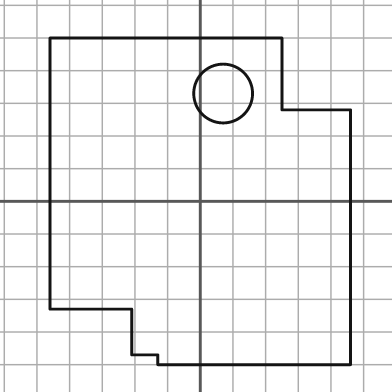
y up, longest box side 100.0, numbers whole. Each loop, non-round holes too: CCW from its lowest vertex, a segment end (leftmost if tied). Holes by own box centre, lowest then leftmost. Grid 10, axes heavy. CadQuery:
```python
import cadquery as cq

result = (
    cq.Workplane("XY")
    .moveTo(-13.0, -50.0)
    .lineTo(46.0, -50.0)
    .lineTo(46.0, 28.0)
    .lineTo(25.0, 28.0)
    .lineTo(25.0, 50.0)
    .lineTo(-46.0, 50.0)
    .lineTo(-46.0, -33.0)
    .lineTo(-21.0, -33.0)
    .lineTo(-21.0, -47.0)
    .lineTo(-13.0, -47.0)
    .close()
    .moveTo(7.0, 33.0)
    .circle(9.0)
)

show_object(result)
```